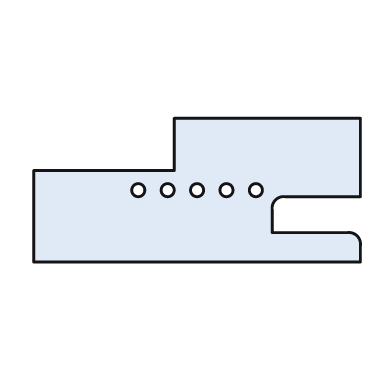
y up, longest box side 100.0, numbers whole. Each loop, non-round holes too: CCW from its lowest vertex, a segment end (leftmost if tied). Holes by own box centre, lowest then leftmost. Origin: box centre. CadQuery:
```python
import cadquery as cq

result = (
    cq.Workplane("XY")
    .moveTo(-50.0, -22.0)
    .lineTo(50.0, -22.0)
    .lineTo(50.0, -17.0)
    .threePointArc((49.0, -14.0), (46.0, -13.0))
    .lineTo(23.0, -13.0)
    .lineTo(23.0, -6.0)
    .threePointArc((24.0, -3.0), (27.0, -2.0))
    .lineTo(50.0, -2.0)
    .lineTo(50.0, 22.0)
    .lineTo(-7.0, 22.0)
    .lineTo(-7.0, 6.0)
    .lineTo(-50.0, 6.0)
    .close()
    .moveTo(-18.0, 0.0)
    .circle(2.0)
    .moveTo(-9.0, 0.0)
    .circle(2.0)
    .moveTo(0.0, 0.0)
    .circle(2.0)
    .moveTo(9.0, 0.0)
    .circle(2.0)
    .moveTo(18.0, 0.0)
    .circle(2.0)
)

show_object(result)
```